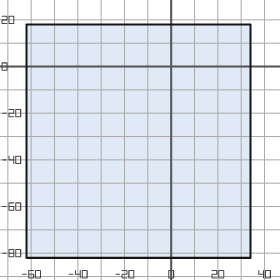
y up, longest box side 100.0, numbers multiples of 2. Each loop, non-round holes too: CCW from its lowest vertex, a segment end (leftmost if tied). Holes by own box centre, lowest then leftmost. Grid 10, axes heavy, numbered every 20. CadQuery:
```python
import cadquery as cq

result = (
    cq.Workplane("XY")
    .moveTo(-62.0, -82.0)
    .lineTo(34.0, -82.0)
    .lineTo(34.0, 18.0)
    .lineTo(-62.0, 18.0)
    .close()
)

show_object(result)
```